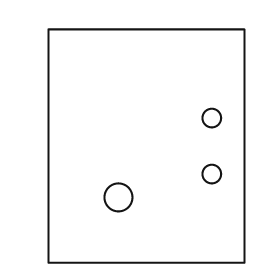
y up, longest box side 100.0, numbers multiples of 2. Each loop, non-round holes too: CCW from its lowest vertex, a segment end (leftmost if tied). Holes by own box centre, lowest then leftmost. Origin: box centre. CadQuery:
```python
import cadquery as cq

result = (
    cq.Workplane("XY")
    .moveTo(-42.0, -50.0)
    .lineTo(42.0, -50.0)
    .lineTo(42.0, 50.0)
    .lineTo(-42.0, 50.0)
    .close()
    .moveTo(-12.0, -22.0)
    .circle(6.0)
    .moveTo(28.0, -12.0)
    .circle(4.0)
    .moveTo(28.0, 12.0)
    .circle(4.0)
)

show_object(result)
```